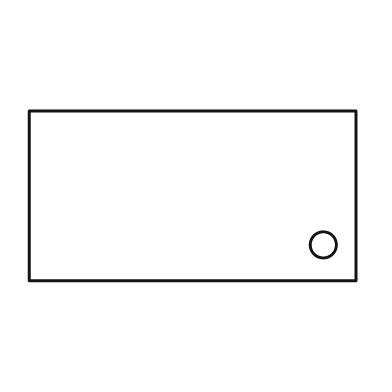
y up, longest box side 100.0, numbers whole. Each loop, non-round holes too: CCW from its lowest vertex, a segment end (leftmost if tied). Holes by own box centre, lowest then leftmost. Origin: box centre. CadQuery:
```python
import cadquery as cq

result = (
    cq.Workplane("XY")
    .moveTo(-50.0, -26.0)
    .lineTo(50.0, -26.0)
    .lineTo(50.0, 26.0)
    .lineTo(-50.0, 26.0)
    .close()
    .moveTo(40.0, -15.0)
    .circle(4.0)
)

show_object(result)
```